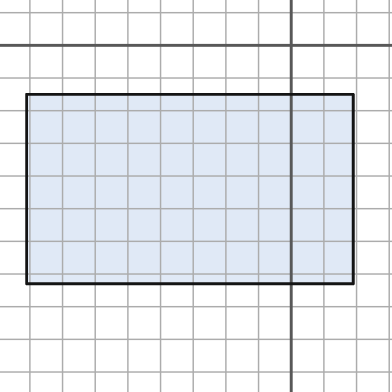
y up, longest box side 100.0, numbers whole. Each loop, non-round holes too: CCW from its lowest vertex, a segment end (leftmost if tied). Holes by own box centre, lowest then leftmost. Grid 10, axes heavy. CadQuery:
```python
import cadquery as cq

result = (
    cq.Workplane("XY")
    .moveTo(-81.0, -73.0)
    .lineTo(19.0, -73.0)
    .lineTo(19.0, -15.0)
    .lineTo(-81.0, -15.0)
    .close()
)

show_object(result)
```